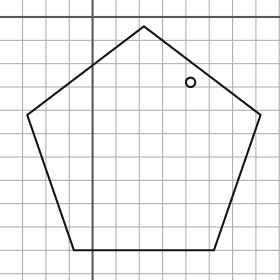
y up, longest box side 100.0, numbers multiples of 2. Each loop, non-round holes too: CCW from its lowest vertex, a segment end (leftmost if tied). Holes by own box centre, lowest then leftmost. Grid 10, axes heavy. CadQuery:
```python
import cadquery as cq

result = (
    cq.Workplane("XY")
    .moveTo(-8.0, -100.0)
    .lineTo(52.0, -100.0)
    .lineTo(72.0, -42.0)
    .lineTo(22.0, -4.0)
    .lineTo(-28.0, -42.0)
    .close()
    .moveTo(42.0, -28.0)
    .circle(2.0)
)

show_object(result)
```